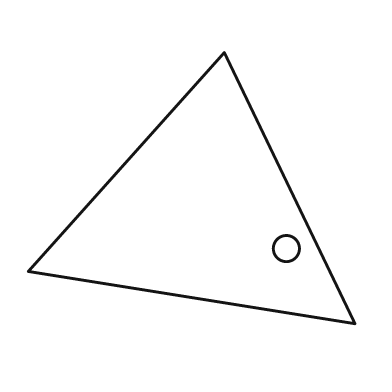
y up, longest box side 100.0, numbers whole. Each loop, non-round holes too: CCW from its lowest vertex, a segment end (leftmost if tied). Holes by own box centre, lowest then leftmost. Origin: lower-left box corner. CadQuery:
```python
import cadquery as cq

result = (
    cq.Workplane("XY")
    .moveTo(100.0, 0.0)
    .lineTo(60.0, 83.0)
    .lineTo(0.0, 16.0)
    .close()
    .moveTo(79.0, 23.0)
    .circle(4.0)
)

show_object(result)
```